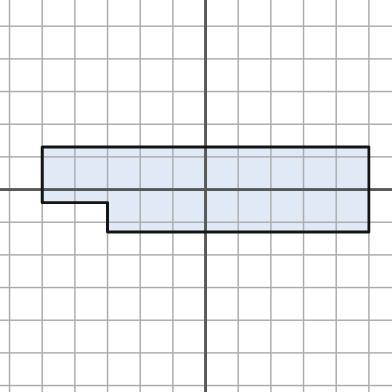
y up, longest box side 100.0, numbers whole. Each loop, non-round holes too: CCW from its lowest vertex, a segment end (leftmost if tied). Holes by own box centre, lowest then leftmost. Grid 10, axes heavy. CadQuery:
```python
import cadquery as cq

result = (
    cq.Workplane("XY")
    .moveTo(-30.0, -13.0)
    .lineTo(50.0, -13.0)
    .lineTo(50.0, 13.0)
    .lineTo(-50.0, 13.0)
    .lineTo(-50.0, -4.0)
    .lineTo(-30.0, -4.0)
    .close()
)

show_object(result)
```